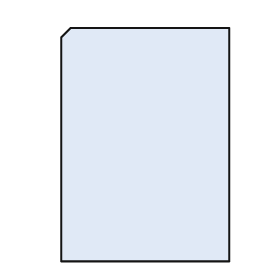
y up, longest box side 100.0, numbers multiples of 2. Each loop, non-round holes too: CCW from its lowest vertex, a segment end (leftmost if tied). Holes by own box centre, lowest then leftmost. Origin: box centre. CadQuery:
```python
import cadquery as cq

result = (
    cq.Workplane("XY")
    .moveTo(-36.0, -50.0)
    .lineTo(36.0, -50.0)
    .lineTo(36.0, 50.0)
    .lineTo(-32.0, 50.0)
    .lineTo(-36.0, 46.0)
    .close()
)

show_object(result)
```